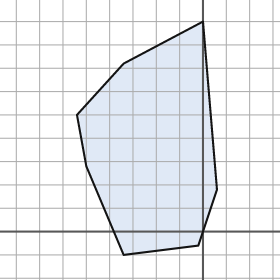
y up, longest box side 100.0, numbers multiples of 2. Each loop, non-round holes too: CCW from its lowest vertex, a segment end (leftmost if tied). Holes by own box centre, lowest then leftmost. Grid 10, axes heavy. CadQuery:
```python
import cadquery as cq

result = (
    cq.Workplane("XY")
    .moveTo(-34.0, -10.0)
    .lineTo(-2.0, -6.0)
    .lineTo(6.0, 18.0)
    .lineTo(0.0, 90.0)
    .lineTo(-34.0, 72.0)
    .lineTo(-54.0, 50.0)
    .lineTo(-50.0, 28.0)
    .close()
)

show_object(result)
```